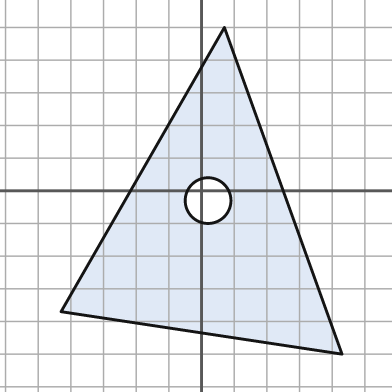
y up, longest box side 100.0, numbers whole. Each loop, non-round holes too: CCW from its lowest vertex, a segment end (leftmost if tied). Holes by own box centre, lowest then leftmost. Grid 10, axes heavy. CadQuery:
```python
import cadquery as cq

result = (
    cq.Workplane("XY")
    .moveTo(43.0, -50.0)
    .lineTo(7.0, 50.0)
    .lineTo(-43.0, -37.0)
    .close()
    .moveTo(2.0, -3.0)
    .circle(7.0)
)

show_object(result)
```